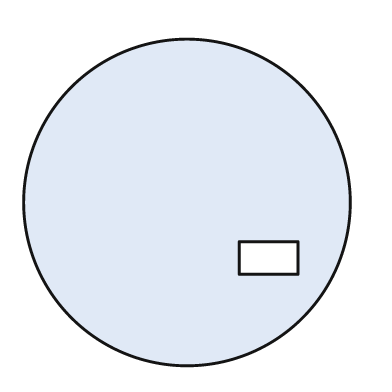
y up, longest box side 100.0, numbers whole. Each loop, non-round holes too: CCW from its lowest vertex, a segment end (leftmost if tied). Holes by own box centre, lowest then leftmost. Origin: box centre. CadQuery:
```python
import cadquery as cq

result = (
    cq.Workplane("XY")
    .moveTo(0.0, 0.0)
    .circle(50.0)
    .moveTo(16.0, -22.0)
    .lineTo(34.0, -22.0)
    .lineTo(34.0, -12.0)
    .lineTo(16.0, -12.0)
    .close()
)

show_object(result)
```